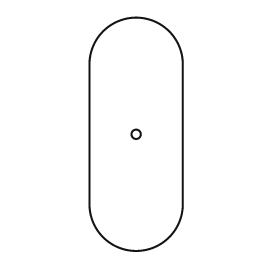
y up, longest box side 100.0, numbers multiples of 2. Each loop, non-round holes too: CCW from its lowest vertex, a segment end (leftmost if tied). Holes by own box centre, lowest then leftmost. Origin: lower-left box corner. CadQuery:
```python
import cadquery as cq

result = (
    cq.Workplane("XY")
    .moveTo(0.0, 20.0)
    .threePointArc((20.0, 0.0), (40.0, 20.0))
    .lineTo(40.0, 80.0)
    .threePointArc((20.0, 100.0), (0.0, 80.0))
    .close()
    .moveTo(20.0, 50.0)
    .circle(2.0)
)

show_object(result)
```